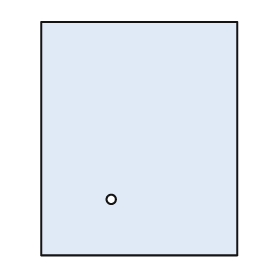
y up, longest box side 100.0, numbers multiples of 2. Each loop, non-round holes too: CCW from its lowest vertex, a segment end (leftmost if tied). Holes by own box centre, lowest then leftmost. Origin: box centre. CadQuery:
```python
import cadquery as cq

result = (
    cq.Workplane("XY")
    .moveTo(-42.0, -50.0)
    .lineTo(42.0, -50.0)
    .lineTo(42.0, 50.0)
    .lineTo(-42.0, 50.0)
    .close()
    .moveTo(-12.0, -26.0)
    .circle(2.0)
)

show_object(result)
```